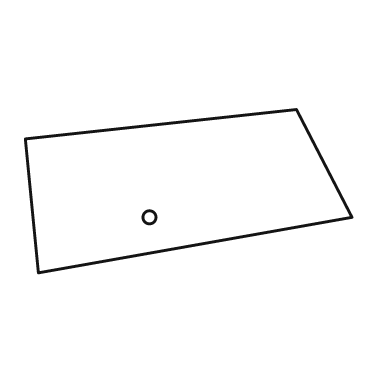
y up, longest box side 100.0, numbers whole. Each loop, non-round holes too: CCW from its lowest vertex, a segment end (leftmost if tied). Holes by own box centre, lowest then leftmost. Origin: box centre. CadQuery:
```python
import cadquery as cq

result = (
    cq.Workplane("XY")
    .moveTo(-46.0, -25.0)
    .lineTo(50.0, -8.0)
    .lineTo(33.0, 25.0)
    .lineTo(-50.0, 16.0)
    .close()
    .moveTo(-12.0, -8.0)
    .circle(2.0)
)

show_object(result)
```